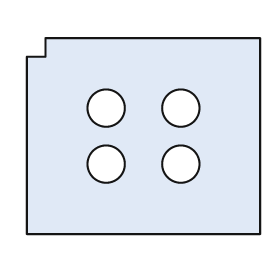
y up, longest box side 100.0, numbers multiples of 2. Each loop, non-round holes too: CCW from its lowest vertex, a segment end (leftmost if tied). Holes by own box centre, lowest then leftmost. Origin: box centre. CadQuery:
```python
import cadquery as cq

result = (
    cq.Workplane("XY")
    .moveTo(-50.0, -42.0)
    .lineTo(50.0, -42.0)
    .lineTo(50.0, 42.0)
    .lineTo(-42.0, 42.0)
    .lineTo(-42.0, 34.0)
    .lineTo(-50.0, 34.0)
    .close()
    .moveTo(-16.0, -12.0)
    .circle(8.0)
    .moveTo(16.0, -12.0)
    .circle(8.0)
    .moveTo(-16.0, 12.0)
    .circle(8.0)
    .moveTo(16.0, 12.0)
    .circle(8.0)
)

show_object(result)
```